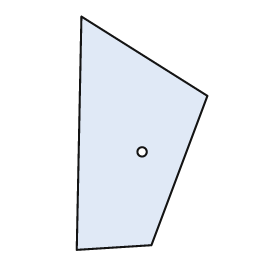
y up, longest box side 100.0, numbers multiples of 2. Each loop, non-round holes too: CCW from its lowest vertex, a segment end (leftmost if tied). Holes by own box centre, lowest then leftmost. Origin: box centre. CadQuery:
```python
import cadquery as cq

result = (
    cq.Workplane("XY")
    .moveTo(-28.0, -50.0)
    .lineTo(4.0, -48.0)
    .lineTo(28.0, 16.0)
    .lineTo(-26.0, 50.0)
    .close()
    .moveTo(0.0, -8.0)
    .circle(2.0)
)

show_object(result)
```